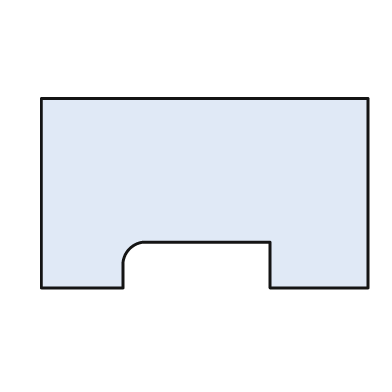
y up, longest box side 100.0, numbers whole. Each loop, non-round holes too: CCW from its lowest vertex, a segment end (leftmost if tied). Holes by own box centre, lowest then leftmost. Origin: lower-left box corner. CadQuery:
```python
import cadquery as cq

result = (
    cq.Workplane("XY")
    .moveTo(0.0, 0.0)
    .lineTo(25.0, 0.0)
    .lineTo(25.0, 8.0)
    .threePointArc((27.0, 12.0), (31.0, 14.0))
    .lineTo(70.0, 14.0)
    .lineTo(70.0, 0.0)
    .lineTo(100.0, 0.0)
    .lineTo(100.0, 58.0)
    .lineTo(0.0, 58.0)
    .close()
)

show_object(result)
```